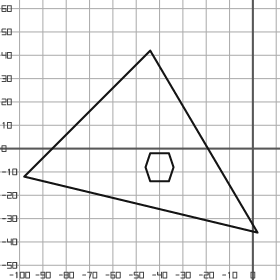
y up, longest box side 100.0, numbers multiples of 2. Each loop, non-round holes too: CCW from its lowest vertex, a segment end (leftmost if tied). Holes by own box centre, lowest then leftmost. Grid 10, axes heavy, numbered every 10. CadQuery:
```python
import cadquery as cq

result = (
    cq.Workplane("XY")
    .moveTo(2.0, -36.0)
    .lineTo(-44.0, 42.0)
    .lineTo(-98.0, -12.0)
    .close()
    .moveTo(-44.0, -14.0)
    .lineTo(-36.0, -14.0)
    .lineTo(-34.0, -8.0)
    .lineTo(-36.0, -2.0)
    .lineTo(-44.0, -2.0)
    .lineTo(-46.0, -8.0)
    .close()
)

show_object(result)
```